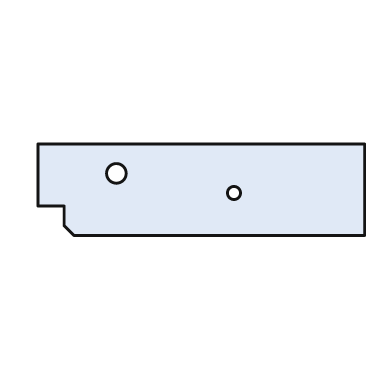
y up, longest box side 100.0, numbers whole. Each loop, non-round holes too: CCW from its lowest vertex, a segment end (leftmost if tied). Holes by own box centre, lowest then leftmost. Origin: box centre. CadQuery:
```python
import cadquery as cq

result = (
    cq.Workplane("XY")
    .moveTo(-39.0, -14.0)
    .lineTo(50.0, -14.0)
    .lineTo(50.0, 14.0)
    .lineTo(-50.0, 14.0)
    .lineTo(-50.0, -5.0)
    .lineTo(-42.0, -5.0)
    .lineTo(-42.0, -11.0)
    .close()
    .moveTo(10.0, -1.0)
    .circle(2.0)
    .moveTo(-26.0, 5.0)
    .circle(3.0)
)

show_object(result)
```